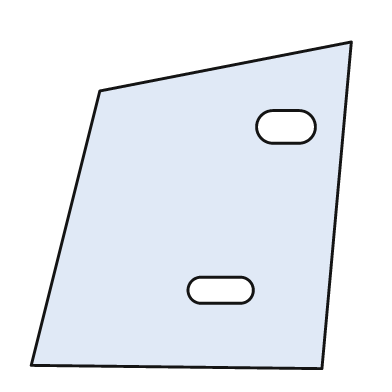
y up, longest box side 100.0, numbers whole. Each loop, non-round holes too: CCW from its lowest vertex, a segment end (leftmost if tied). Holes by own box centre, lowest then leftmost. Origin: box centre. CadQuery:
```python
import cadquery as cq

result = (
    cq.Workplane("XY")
    .moveTo(40.0, -50.0)
    .lineTo(49.0, 50.0)
    .lineTo(-28.0, 35.0)
    .lineTo(-49.0, -49.0)
    .close()
    .moveTo(3.0, -30.0)
    .lineTo(15.0, -30.0)
    .threePointArc((19.0, -26.0), (15.0, -22.0))
    .lineTo(3.0, -22.0)
    .threePointArc((-1.0, -26.0), (3.0, -30.0))
    .close()
    .moveTo(25.0, 19.0)
    .lineTo(33.0, 19.0)
    .threePointArc((38.0, 24.0), (33.0, 29.0))
    .lineTo(25.0, 29.0)
    .threePointArc((20.0, 24.0), (25.0, 19.0))
    .close()
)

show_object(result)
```